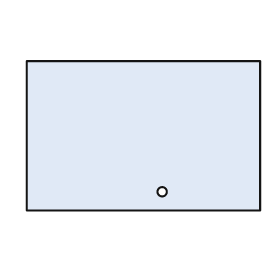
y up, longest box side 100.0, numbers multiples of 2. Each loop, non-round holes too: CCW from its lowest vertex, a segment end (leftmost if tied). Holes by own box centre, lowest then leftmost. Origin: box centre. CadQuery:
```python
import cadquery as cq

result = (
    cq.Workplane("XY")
    .moveTo(-50.0, -32.0)
    .lineTo(50.0, -32.0)
    .lineTo(50.0, 32.0)
    .lineTo(-50.0, 32.0)
    .close()
    .moveTo(8.0, -24.0)
    .circle(2.0)
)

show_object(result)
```